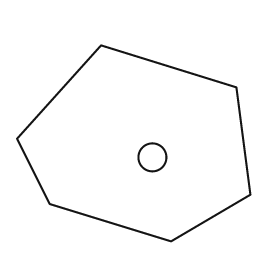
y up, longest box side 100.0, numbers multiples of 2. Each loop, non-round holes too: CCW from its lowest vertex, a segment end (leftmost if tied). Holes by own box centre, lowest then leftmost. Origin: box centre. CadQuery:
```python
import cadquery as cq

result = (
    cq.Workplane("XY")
    .moveTo(16.0, -42.0)
    .lineTo(50.0, -22.0)
    .lineTo(44.0, 24.0)
    .lineTo(-14.0, 42.0)
    .lineTo(-50.0, 2.0)
    .lineTo(-36.0, -26.0)
    .close()
    .moveTo(8.0, -6.0)
    .circle(6.0)
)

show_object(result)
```